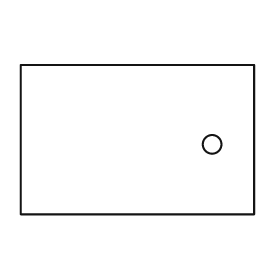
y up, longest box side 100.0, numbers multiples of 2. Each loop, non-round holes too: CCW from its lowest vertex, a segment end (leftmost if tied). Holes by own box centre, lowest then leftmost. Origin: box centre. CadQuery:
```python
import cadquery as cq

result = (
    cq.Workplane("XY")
    .moveTo(-50.0, -32.0)
    .lineTo(50.0, -32.0)
    .lineTo(50.0, 32.0)
    .lineTo(-50.0, 32.0)
    .close()
    .moveTo(32.0, -2.0)
    .circle(4.0)
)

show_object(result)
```